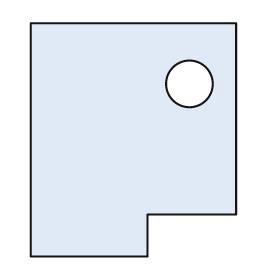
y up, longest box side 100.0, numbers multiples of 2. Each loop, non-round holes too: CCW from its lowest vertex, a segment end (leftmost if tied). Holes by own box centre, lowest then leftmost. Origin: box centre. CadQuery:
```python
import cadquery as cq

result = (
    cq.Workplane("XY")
    .moveTo(-44.0, -50.0)
    .lineTo(6.0, -50.0)
    .lineTo(6.0, -32.0)
    .lineTo(44.0, -32.0)
    .lineTo(44.0, 50.0)
    .lineTo(-44.0, 50.0)
    .close()
    .moveTo(24.0, 24.0)
    .circle(10.0)
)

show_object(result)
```